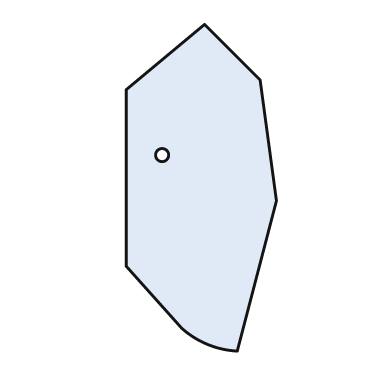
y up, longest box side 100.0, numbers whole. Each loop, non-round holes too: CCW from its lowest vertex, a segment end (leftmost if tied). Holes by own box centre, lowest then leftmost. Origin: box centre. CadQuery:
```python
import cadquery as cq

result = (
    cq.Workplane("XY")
    .moveTo(11.0, -50.0)
    .lineTo(23.0, -4.0)
    .lineTo(18.0, 33.0)
    .lineTo(1.0, 50.0)
    .lineTo(-23.0, 30.0)
    .lineTo(-23.0, -24.0)
    .lineTo(-6.0, -43.0)
    .threePointArc((2.0, -48.0), (11.0, -50.0))
    .close()
    .moveTo(-12.0, 10.0)
    .circle(2.0)
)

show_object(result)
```